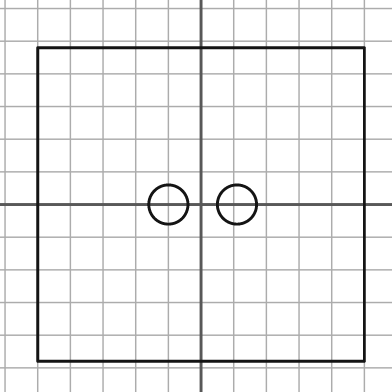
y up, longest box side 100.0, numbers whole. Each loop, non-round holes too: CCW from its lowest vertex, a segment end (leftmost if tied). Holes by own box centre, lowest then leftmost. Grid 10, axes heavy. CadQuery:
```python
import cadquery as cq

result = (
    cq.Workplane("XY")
    .moveTo(-50.0, -48.0)
    .lineTo(50.0, -48.0)
    .lineTo(50.0, 48.0)
    .lineTo(-50.0, 48.0)
    .close()
    .moveTo(-10.0, 0.0)
    .circle(6.0)
    .moveTo(11.0, 0.0)
    .circle(6.0)
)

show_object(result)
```